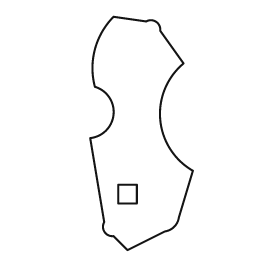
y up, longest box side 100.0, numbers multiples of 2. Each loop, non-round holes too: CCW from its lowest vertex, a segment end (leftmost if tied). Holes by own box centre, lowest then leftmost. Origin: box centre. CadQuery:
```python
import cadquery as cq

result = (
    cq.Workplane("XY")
    .moveTo(-6.0, -50.0)
    .lineTo(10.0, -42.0)
    .threePointArc((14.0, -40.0), (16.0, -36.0))
    .lineTo(22.0, -16.0)
    .threePointArc((8.0, 6.0), (18.0, 30.0))
    .lineTo(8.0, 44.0)
    .threePointArc((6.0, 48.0), (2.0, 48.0))
    .lineTo(-12.0, 50.0)
    .threePointArc((-20.0, 36.0), (-20.0, 20.0))
    .threePointArc((-12.0, 8.0), (-22.0, -2.0))
    .lineTo(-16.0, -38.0)
    .threePointArc((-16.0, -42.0), (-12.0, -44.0))
    .close()
    .moveTo(-10.0, -30.0)
    .lineTo(-2.0, -30.0)
    .lineTo(-2.0, -22.0)
    .lineTo(-10.0, -22.0)
    .close()
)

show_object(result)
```